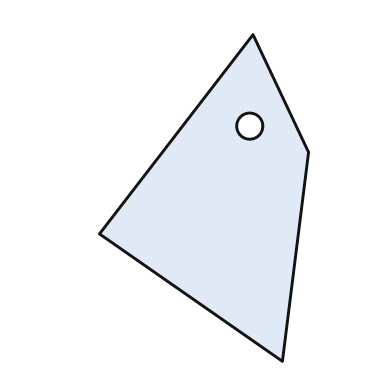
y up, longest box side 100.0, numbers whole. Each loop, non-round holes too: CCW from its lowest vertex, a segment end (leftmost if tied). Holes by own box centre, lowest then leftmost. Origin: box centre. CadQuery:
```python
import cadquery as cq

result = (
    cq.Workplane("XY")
    .moveTo(24.0, -50.0)
    .lineTo(32.0, 14.0)
    .lineTo(15.0, 50.0)
    .lineTo(-32.0, -11.0)
    .close()
    .moveTo(14.0, 22.0)
    .circle(4.0)
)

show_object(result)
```